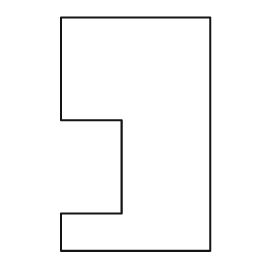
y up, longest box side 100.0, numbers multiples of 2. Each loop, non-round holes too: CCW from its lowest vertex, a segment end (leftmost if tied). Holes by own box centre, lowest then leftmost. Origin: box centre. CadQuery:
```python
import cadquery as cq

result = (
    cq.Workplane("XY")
    .moveTo(-32.0, -50.0)
    .lineTo(32.0, -50.0)
    .lineTo(32.0, 50.0)
    .lineTo(-32.0, 50.0)
    .lineTo(-32.0, 6.0)
    .lineTo(-6.0, 6.0)
    .lineTo(-6.0, -34.0)
    .lineTo(-32.0, -34.0)
    .close()
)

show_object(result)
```